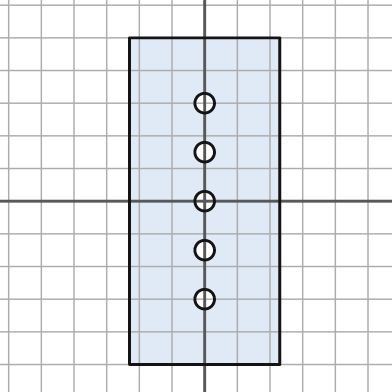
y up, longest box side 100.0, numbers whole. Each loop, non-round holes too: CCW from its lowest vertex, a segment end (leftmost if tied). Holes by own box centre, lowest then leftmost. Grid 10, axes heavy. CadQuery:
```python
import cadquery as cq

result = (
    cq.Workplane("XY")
    .moveTo(-23.0, -50.0)
    .lineTo(23.0, -50.0)
    .lineTo(23.0, 50.0)
    .lineTo(-23.0, 50.0)
    .close()
    .moveTo(0.0, -30.0)
    .circle(3.0)
    .moveTo(0.0, -15.0)
    .circle(3.0)
    .moveTo(0.0, 0.0)
    .circle(3.0)
    .moveTo(0.0, 15.0)
    .circle(3.0)
    .moveTo(0.0, 30.0)
    .circle(3.0)
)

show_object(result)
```